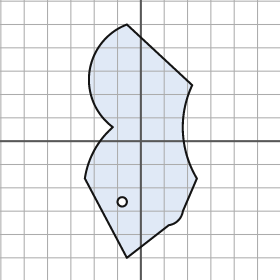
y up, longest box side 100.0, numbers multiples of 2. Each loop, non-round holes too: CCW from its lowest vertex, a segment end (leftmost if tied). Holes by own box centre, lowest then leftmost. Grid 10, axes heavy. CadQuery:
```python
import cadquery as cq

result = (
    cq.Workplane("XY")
    .moveTo(-6.0, -50.0)
    .lineTo(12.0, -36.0)
    .threePointArc((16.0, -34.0), (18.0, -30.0))
    .lineTo(24.0, -16.0)
    .threePointArc((18.0, 4.0), (22.0, 24.0))
    .lineTo(-6.0, 50.0)
    .threePointArc((-22.0, 30.0), (-12.0, 6.0))
    .threePointArc((-20.0, -4.0), (-24.0, -16.0))
    .close()
    .moveTo(-8.0, -26.0)
    .circle(2.0)
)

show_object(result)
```